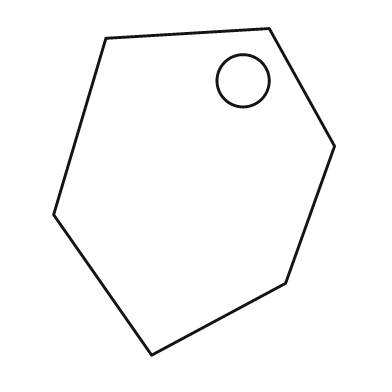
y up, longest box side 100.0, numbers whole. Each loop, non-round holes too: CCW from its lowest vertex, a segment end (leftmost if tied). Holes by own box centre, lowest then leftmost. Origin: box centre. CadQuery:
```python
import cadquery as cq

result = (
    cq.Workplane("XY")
    .moveTo(-13.0, -50.0)
    .lineTo(28.0, -28.0)
    .lineTo(43.0, 14.0)
    .lineTo(23.0, 50.0)
    .lineTo(-27.0, 47.0)
    .lineTo(-43.0, -7.0)
    .close()
    .moveTo(15.0, 34.0)
    .circle(8.0)
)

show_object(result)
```